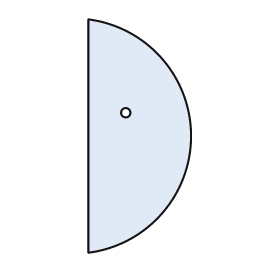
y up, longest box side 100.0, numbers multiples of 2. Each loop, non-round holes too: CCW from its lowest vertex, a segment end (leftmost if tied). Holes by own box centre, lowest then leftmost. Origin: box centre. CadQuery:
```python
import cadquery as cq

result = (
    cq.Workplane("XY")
    .moveTo(-22.0, -50.0)
    .threePointArc((22.0, 0.0), (-22.0, 50.0))
    .close()
    .moveTo(-6.0, 10.0)
    .circle(2.0)
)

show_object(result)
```